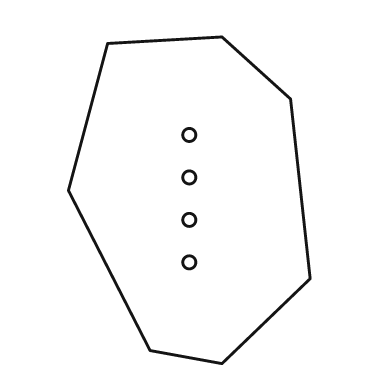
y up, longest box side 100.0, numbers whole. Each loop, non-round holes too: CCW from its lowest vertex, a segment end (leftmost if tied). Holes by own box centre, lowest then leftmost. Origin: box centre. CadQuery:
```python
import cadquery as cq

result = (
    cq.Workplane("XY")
    .moveTo(10.0, -50.0)
    .lineTo(37.0, -24.0)
    .lineTo(31.0, 31.0)
    .lineTo(10.0, 50.0)
    .lineTo(-25.0, 48.0)
    .lineTo(-37.0, 3.0)
    .lineTo(-12.0, -46.0)
    .close()
    .moveTo(0.0, -19.0)
    .circle(2.0)
    .moveTo(0.0, -6.0)
    .circle(2.0)
    .moveTo(0.0, 7.0)
    .circle(2.0)
    .moveTo(0.0, 20.0)
    .circle(2.0)
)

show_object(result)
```